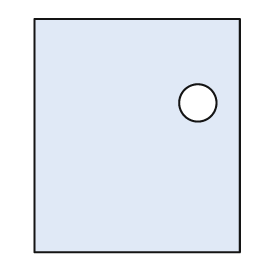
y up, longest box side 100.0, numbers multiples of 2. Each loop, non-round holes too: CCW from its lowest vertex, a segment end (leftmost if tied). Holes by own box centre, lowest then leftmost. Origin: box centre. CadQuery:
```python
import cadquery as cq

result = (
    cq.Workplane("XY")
    .moveTo(-44.0, -50.0)
    .lineTo(44.0, -50.0)
    .lineTo(44.0, 50.0)
    .lineTo(-44.0, 50.0)
    .close()
    .moveTo(26.0, 14.0)
    .circle(8.0)
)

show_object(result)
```